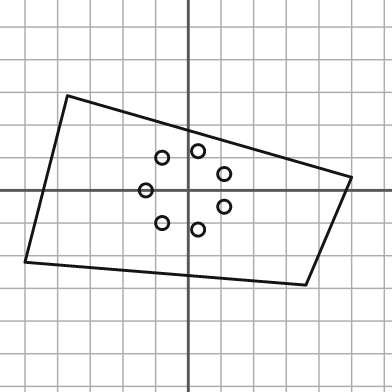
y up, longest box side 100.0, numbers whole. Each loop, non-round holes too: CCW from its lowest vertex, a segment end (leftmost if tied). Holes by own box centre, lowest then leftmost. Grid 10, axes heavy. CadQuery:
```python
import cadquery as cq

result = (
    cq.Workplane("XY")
    .moveTo(36.0, -29.0)
    .lineTo(50.0, 4.0)
    .lineTo(-37.0, 29.0)
    .lineTo(-50.0, -22.0)
    .close()
    .moveTo(3.0, -12.0)
    .circle(2.0)
    .moveTo(-8.0, -10.0)
    .circle(2.0)
    .moveTo(11.0, -5.0)
    .circle(2.0)
    .moveTo(-13.0, 0.0)
    .circle(2.0)
    .moveTo(11.0, 5.0)
    .circle(2.0)
    .moveTo(-8.0, 10.0)
    .circle(2.0)
    .moveTo(3.0, 12.0)
    .circle(2.0)
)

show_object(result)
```